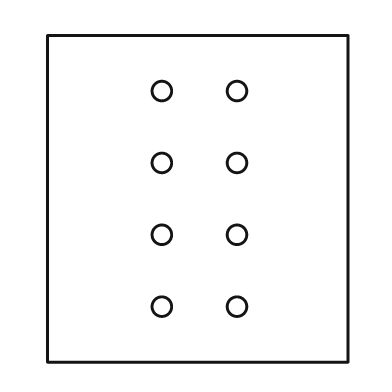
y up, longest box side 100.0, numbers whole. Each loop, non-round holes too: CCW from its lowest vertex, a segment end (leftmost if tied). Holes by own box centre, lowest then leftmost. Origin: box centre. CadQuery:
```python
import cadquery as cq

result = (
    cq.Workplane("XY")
    .moveTo(-46.0, -50.0)
    .lineTo(46.0, -50.0)
    .lineTo(46.0, 50.0)
    .lineTo(-46.0, 50.0)
    .close()
    .moveTo(-11.0, -33.0)
    .circle(3.0)
    .moveTo(12.0, -33.0)
    .circle(3.0)
    .moveTo(-11.0, -11.0)
    .circle(3.0)
    .moveTo(12.0, -11.0)
    .circle(3.0)
    .moveTo(-11.0, 11.0)
    .circle(3.0)
    .moveTo(12.0, 11.0)
    .circle(3.0)
    .moveTo(-11.0, 33.0)
    .circle(3.0)
    .moveTo(12.0, 33.0)
    .circle(3.0)
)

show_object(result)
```